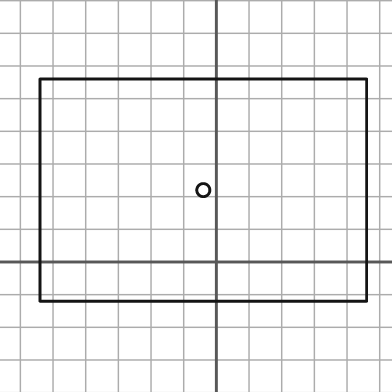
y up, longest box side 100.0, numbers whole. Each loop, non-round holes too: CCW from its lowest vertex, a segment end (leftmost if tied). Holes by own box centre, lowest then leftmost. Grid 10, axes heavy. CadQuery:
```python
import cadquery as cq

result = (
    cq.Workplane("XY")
    .moveTo(-54.0, -12.0)
    .lineTo(46.0, -12.0)
    .lineTo(46.0, 56.0)
    .lineTo(-54.0, 56.0)
    .close()
    .moveTo(-4.0, 22.0)
    .circle(2.0)
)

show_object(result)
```